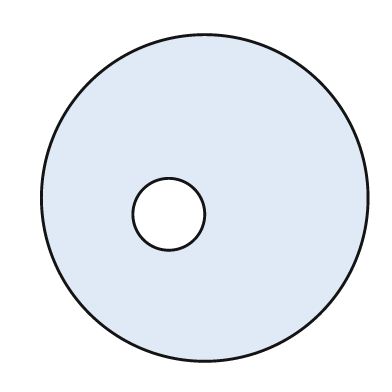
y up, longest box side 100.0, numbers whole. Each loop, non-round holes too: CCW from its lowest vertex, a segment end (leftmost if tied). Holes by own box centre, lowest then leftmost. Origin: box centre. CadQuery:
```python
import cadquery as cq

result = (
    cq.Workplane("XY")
    .moveTo(0.0, 0.0)
    .circle(50.0)
    .moveTo(-11.0, -5.0)
    .circle(11.0)
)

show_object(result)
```